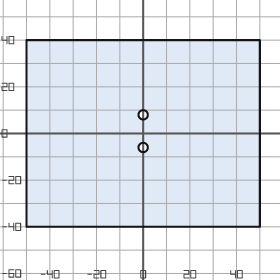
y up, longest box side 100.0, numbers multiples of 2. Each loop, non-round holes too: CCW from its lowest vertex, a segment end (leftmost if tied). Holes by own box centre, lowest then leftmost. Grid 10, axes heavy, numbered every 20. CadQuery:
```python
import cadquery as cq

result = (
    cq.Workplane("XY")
    .moveTo(-50.0, -40.0)
    .lineTo(50.0, -40.0)
    .lineTo(50.0, 40.0)
    .lineTo(-50.0, 40.0)
    .close()
    .moveTo(0.0, -6.0)
    .circle(2.0)
    .moveTo(0.0, 8.0)
    .circle(2.0)
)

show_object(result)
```